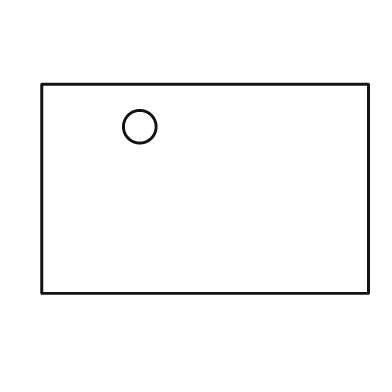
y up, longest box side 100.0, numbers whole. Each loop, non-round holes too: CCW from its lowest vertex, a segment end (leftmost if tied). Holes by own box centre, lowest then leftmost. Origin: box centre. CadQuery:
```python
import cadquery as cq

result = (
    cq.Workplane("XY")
    .moveTo(-50.0, -32.0)
    .lineTo(50.0, -32.0)
    .lineTo(50.0, 32.0)
    .lineTo(-50.0, 32.0)
    .close()
    .moveTo(-20.0, 19.0)
    .circle(5.0)
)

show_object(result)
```